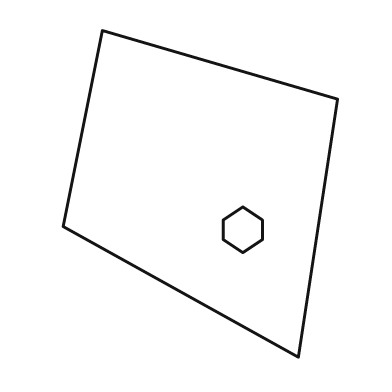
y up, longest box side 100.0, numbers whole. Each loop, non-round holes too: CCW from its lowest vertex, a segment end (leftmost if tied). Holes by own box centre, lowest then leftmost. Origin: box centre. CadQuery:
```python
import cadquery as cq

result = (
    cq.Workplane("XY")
    .moveTo(30.0, -50.0)
    .lineTo(42.0, 29.0)
    .lineTo(-30.0, 50.0)
    .lineTo(-42.0, -10.0)
    .close()
    .moveTo(13.0, -18.0)
    .lineTo(19.0, -14.0)
    .lineTo(19.0, -8.0)
    .lineTo(13.0, -4.0)
    .lineTo(7.0, -8.0)
    .lineTo(7.0, -14.0)
    .close()
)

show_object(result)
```